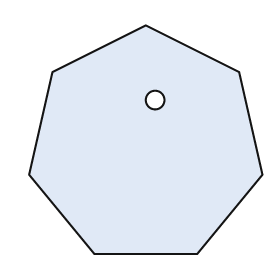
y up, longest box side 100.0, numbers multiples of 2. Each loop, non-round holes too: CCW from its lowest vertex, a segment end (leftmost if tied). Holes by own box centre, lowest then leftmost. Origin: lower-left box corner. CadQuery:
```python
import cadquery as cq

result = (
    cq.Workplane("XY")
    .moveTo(28.0, 0.0)
    .lineTo(72.0, 0.0)
    .lineTo(100.0, 34.0)
    .lineTo(90.0, 78.0)
    .lineTo(50.0, 98.0)
    .lineTo(10.0, 78.0)
    .lineTo(0.0, 34.0)
    .close()
    .moveTo(54.0, 66.0)
    .circle(4.0)
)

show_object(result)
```